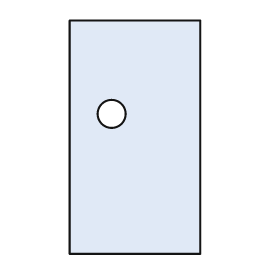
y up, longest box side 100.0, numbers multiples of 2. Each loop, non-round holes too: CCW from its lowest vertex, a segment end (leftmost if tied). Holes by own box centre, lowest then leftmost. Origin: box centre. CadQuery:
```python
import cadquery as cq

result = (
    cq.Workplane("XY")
    .moveTo(-28.0, -50.0)
    .lineTo(28.0, -50.0)
    .lineTo(28.0, 50.0)
    .lineTo(-28.0, 50.0)
    .close()
    .moveTo(-10.0, 10.0)
    .circle(6.0)
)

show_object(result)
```